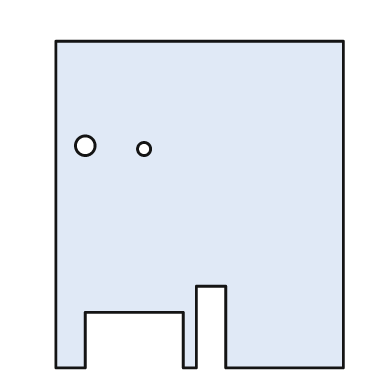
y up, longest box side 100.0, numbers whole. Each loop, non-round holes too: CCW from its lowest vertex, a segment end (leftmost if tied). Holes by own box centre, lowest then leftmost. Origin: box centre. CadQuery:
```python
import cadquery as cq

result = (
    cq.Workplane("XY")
    .moveTo(-44.0, -50.0)
    .lineTo(-35.0, -50.0)
    .lineTo(-35.0, -33.0)
    .lineTo(-5.0, -33.0)
    .lineTo(-5.0, -50.0)
    .lineTo(-1.0, -50.0)
    .lineTo(-1.0, -25.0)
    .lineTo(8.0, -25.0)
    .lineTo(8.0, -50.0)
    .lineTo(44.0, -50.0)
    .lineTo(44.0, 50.0)
    .lineTo(-44.0, 50.0)
    .close()
    .moveTo(-17.0, 17.0)
    .circle(2.0)
    .moveTo(-35.0, 18.0)
    .circle(3.0)
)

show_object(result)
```